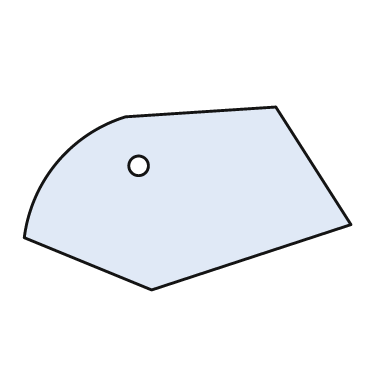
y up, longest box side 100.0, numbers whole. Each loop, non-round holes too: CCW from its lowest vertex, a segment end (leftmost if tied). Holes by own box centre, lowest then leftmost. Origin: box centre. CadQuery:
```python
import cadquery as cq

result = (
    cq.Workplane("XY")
    .moveTo(-11.0, -28.0)
    .lineTo(50.0, -8.0)
    .lineTo(27.0, 28.0)
    .lineTo(-19.0, 25.0)
    .threePointArc((-40.0, 11.0), (-50.0, -12.0))
    .close()
    .moveTo(-15.0, 10.0)
    .circle(3.0)
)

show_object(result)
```